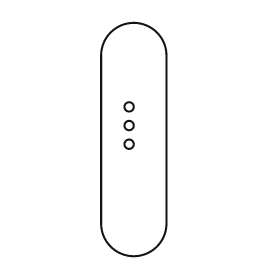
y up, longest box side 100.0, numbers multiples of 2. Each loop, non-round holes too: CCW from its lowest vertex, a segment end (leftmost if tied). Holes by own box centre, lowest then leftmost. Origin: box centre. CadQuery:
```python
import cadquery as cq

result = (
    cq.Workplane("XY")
    .moveTo(-14.0, -36.0)
    .threePointArc((0.0, -50.0), (14.0, -36.0))
    .lineTo(14.0, 36.0)
    .threePointArc((0.0, 50.0), (-14.0, 36.0))
    .close()
    .moveTo(-2.0, -2.0)
    .circle(2.0)
    .moveTo(-2.0, 6.0)
    .circle(2.0)
    .moveTo(-2.0, 14.0)
    .circle(2.0)
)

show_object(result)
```